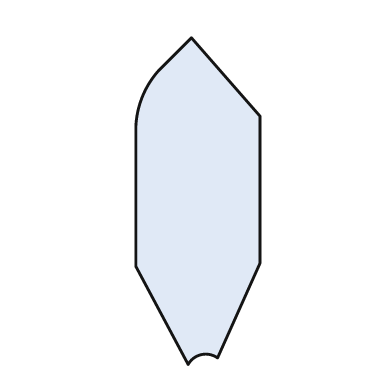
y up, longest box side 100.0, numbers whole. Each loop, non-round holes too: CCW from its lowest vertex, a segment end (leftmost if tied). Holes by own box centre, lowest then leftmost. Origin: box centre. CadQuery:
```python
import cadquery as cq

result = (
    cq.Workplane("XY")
    .moveTo(-3.0, -50.0)
    .threePointArc((1.0, -47.0), (6.0, -48.0))
    .lineTo(19.0, -19.0)
    .lineTo(19.0, 26.0)
    .lineTo(-2.0, 50.0)
    .lineTo(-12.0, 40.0)
    .threePointArc((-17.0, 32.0), (-19.0, 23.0))
    .lineTo(-19.0, -20.0)
    .close()
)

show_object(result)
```